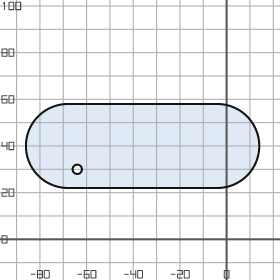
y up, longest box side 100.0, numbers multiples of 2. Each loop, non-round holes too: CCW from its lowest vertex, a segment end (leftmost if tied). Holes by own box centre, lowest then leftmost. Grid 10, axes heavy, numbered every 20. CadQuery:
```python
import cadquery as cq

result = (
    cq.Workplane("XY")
    .moveTo(-68.0, 22.0)
    .lineTo(-4.0, 22.0)
    .threePointArc((14.0, 40.0), (-4.0, 58.0))
    .lineTo(-68.0, 58.0)
    .threePointArc((-86.0, 40.0), (-68.0, 22.0))
    .close()
    .moveTo(-64.0, 30.0)
    .circle(2.0)
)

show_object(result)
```